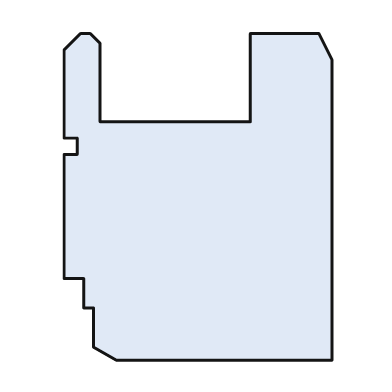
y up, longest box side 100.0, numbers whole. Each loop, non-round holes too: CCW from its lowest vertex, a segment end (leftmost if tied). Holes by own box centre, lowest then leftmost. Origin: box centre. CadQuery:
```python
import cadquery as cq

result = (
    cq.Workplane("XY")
    .moveTo(-25.0, -50.0)
    .lineTo(41.0, -50.0)
    .lineTo(41.0, 42.0)
    .lineTo(37.0, 50.0)
    .lineTo(16.0, 50.0)
    .lineTo(16.0, 23.0)
    .lineTo(-30.0, 23.0)
    .lineTo(-30.0, 47.0)
    .lineTo(-33.0, 50.0)
    .lineTo(-36.0, 50.0)
    .lineTo(-41.0, 45.0)
    .lineTo(-41.0, 18.0)
    .lineTo(-37.0, 18.0)
    .lineTo(-37.0, 13.0)
    .lineTo(-41.0, 13.0)
    .lineTo(-41.0, -25.0)
    .lineTo(-35.0, -25.0)
    .lineTo(-35.0, -34.0)
    .lineTo(-32.0, -34.0)
    .lineTo(-32.0, -46.0)
    .close()
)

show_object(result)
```